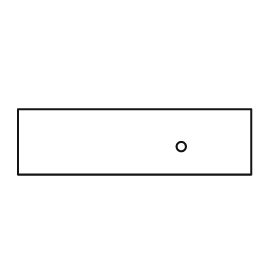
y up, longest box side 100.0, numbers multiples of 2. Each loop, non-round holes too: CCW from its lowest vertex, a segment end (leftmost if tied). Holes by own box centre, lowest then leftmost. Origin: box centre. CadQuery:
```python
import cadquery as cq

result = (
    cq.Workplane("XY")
    .moveTo(-50.0, -14.0)
    .lineTo(50.0, -14.0)
    .lineTo(50.0, 14.0)
    .lineTo(-50.0, 14.0)
    .close()
    .moveTo(20.0, -2.0)
    .circle(2.0)
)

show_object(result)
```